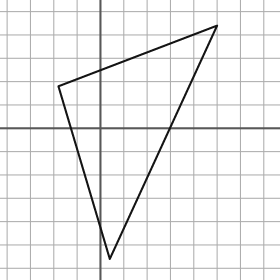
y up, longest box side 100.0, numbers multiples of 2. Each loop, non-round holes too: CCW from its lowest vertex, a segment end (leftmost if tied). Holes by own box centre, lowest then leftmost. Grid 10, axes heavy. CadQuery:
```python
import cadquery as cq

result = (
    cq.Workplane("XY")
    .moveTo(4.0, -56.0)
    .lineTo(50.0, 44.0)
    .lineTo(-18.0, 18.0)
    .close()
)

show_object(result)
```